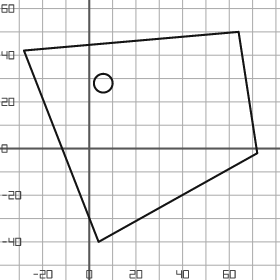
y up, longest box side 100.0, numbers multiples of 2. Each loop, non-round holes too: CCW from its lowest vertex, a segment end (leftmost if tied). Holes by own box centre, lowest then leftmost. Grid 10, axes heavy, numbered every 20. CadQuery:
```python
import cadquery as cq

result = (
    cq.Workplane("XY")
    .moveTo(4.0, -40.0)
    .lineTo(72.0, -2.0)
    .lineTo(64.0, 50.0)
    .lineTo(-28.0, 42.0)
    .close()
    .moveTo(6.0, 28.0)
    .circle(4.0)
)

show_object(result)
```